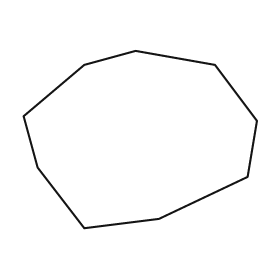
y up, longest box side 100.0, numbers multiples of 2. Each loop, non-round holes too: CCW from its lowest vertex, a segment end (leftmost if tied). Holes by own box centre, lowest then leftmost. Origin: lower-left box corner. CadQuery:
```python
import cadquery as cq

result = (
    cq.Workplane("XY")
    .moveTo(26.0, 0.0)
    .lineTo(58.0, 4.0)
    .lineTo(96.0, 22.0)
    .lineTo(100.0, 46.0)
    .lineTo(82.0, 70.0)
    .lineTo(48.0, 76.0)
    .lineTo(26.0, 70.0)
    .lineTo(0.0, 48.0)
    .lineTo(6.0, 26.0)
    .close()
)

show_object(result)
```